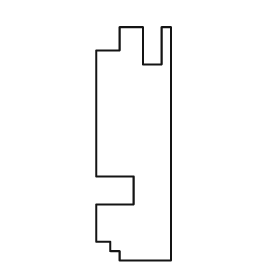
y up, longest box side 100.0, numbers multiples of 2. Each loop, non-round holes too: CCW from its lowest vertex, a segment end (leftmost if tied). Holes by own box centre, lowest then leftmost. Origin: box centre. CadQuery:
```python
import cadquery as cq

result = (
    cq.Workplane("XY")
    .moveTo(-6.0, -50.0)
    .lineTo(16.0, -50.0)
    .lineTo(16.0, 50.0)
    .lineTo(12.0, 50.0)
    .lineTo(12.0, 34.0)
    .lineTo(4.0, 34.0)
    .lineTo(4.0, 50.0)
    .lineTo(-6.0, 50.0)
    .lineTo(-6.0, 40.0)
    .lineTo(-16.0, 40.0)
    .lineTo(-16.0, -14.0)
    .lineTo(0.0, -14.0)
    .lineTo(0.0, -26.0)
    .lineTo(-16.0, -26.0)
    .lineTo(-16.0, -42.0)
    .lineTo(-10.0, -42.0)
    .lineTo(-10.0, -46.0)
    .lineTo(-6.0, -46.0)
    .close()
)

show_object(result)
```